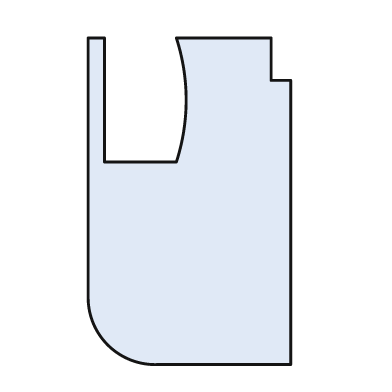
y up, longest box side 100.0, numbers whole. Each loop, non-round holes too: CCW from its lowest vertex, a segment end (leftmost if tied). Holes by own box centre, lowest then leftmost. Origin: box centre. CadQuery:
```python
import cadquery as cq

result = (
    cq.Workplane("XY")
    .moveTo(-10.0, -50.0)
    .lineTo(31.0, -50.0)
    .lineTo(31.0, 37.0)
    .lineTo(25.0, 37.0)
    .lineTo(25.0, 50.0)
    .lineTo(-4.0, 50.0)
    .threePointArc((-1.0, 31.0), (-4.0, 12.0))
    .lineTo(-26.0, 12.0)
    .lineTo(-26.0, 50.0)
    .lineTo(-31.0, 50.0)
    .lineTo(-31.0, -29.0)
    .threePointArc((-25.0, -44.0), (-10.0, -50.0))
    .close()
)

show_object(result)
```